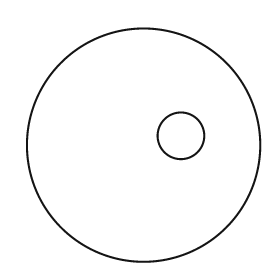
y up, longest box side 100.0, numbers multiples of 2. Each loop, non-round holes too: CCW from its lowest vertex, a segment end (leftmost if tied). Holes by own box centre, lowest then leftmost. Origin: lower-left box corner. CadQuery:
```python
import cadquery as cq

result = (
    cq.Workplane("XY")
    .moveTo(50.0, 50.0)
    .circle(50.0)
    .moveTo(66.0, 54.0)
    .circle(10.0)
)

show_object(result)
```